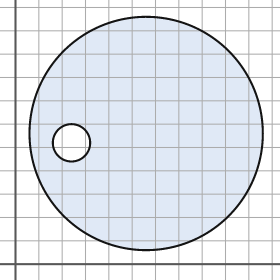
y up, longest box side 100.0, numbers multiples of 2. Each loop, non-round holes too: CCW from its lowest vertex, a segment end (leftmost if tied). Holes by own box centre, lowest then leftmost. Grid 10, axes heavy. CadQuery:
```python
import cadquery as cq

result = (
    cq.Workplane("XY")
    .moveTo(56.0, 56.0)
    .circle(50.0)
    .moveTo(24.0, 52.0)
    .circle(8.0)
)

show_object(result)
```